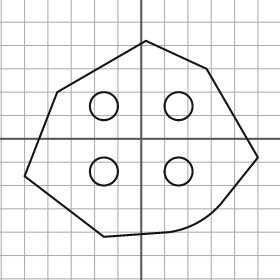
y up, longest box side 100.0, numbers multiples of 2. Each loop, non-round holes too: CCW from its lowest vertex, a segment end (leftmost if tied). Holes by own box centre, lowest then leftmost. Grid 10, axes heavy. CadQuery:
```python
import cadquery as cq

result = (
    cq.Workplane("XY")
    .moveTo(-16.0, -42.0)
    .lineTo(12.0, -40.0)
    .threePointArc((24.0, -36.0), (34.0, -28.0))
    .lineTo(50.0, -8.0)
    .lineTo(28.0, 30.0)
    .lineTo(2.0, 42.0)
    .lineTo(-36.0, 20.0)
    .lineTo(-50.0, -16.0)
    .close()
    .moveTo(-16.0, -14.0)
    .circle(6.0)
    .moveTo(16.0, -14.0)
    .circle(6.0)
    .moveTo(-16.0, 14.0)
    .circle(6.0)
    .moveTo(16.0, 14.0)
    .circle(6.0)
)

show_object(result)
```